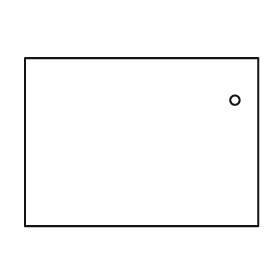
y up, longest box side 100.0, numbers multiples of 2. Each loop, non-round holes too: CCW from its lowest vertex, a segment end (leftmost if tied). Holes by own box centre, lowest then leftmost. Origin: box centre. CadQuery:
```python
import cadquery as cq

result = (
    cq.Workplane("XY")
    .moveTo(-50.0, -36.0)
    .lineTo(50.0, -36.0)
    .lineTo(50.0, 36.0)
    .lineTo(-50.0, 36.0)
    .close()
    .moveTo(40.0, 18.0)
    .circle(2.0)
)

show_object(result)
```